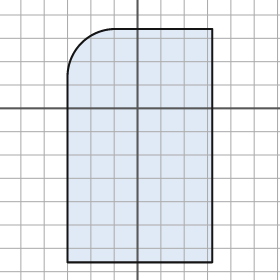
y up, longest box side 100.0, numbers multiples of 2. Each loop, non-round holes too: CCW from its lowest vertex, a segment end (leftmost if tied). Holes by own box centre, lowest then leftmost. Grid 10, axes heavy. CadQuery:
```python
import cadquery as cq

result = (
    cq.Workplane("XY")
    .moveTo(-30.0, -66.0)
    .lineTo(32.0, -66.0)
    .lineTo(32.0, 34.0)
    .lineTo(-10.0, 34.0)
    .threePointArc((-24.0, 28.0), (-30.0, 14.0))
    .close()
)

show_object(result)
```